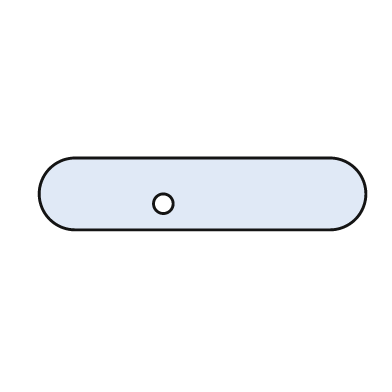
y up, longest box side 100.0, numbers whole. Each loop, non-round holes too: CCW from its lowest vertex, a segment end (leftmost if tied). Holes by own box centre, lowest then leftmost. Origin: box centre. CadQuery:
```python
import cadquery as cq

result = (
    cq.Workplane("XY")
    .moveTo(-39.0, -11.0)
    .lineTo(39.0, -11.0)
    .threePointArc((50.0, 0.0), (39.0, 11.0))
    .lineTo(-39.0, 11.0)
    .threePointArc((-50.0, 0.0), (-39.0, -11.0))
    .close()
    .moveTo(-12.0, -3.0)
    .circle(3.0)
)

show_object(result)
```